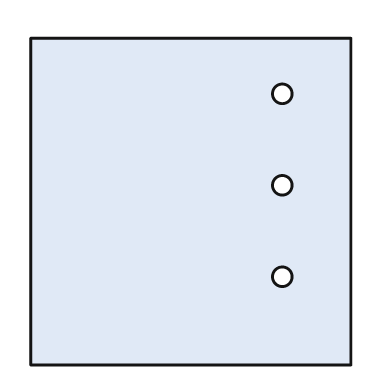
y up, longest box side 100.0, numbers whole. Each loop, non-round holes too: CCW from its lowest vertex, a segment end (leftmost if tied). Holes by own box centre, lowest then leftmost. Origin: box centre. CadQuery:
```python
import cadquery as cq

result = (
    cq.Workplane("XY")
    .moveTo(-49.0, -50.0)
    .lineTo(49.0, -50.0)
    .lineTo(49.0, 50.0)
    .lineTo(-49.0, 50.0)
    .close()
    .moveTo(28.0, -23.0)
    .circle(3.0)
    .moveTo(28.0, 5.0)
    .circle(3.0)
    .moveTo(28.0, 33.0)
    .circle(3.0)
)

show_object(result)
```